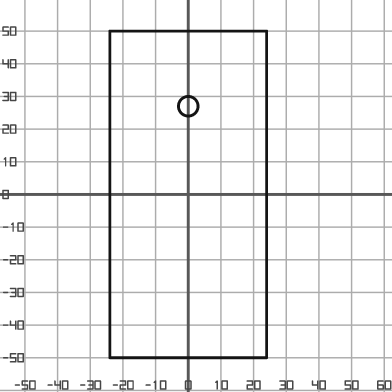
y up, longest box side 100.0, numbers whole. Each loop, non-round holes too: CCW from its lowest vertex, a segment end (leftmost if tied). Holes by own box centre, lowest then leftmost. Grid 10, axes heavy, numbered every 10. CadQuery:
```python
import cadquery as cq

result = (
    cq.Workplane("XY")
    .moveTo(-24.0, -50.0)
    .lineTo(24.0, -50.0)
    .lineTo(24.0, 50.0)
    .lineTo(-24.0, 50.0)
    .close()
    .moveTo(0.0, 27.0)
    .circle(3.0)
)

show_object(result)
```